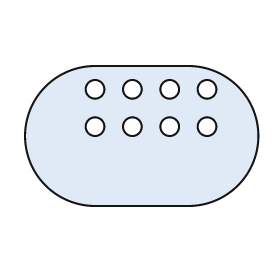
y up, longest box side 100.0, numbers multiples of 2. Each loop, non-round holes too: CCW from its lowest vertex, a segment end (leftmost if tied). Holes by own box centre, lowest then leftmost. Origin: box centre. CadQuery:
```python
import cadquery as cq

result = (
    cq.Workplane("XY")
    .moveTo(-20.0, -30.0)
    .lineTo(20.0, -30.0)
    .threePointArc((50.0, 0.0), (20.0, 30.0))
    .lineTo(-20.0, 30.0)
    .threePointArc((-50.0, 0.0), (-20.0, -30.0))
    .close()
    .moveTo(-20.0, 4.0)
    .circle(4.0)
    .moveTo(-4.0, 4.0)
    .circle(4.0)
    .moveTo(12.0, 4.0)
    .circle(4.0)
    .moveTo(28.0, 4.0)
    .circle(4.0)
    .moveTo(-20.0, 20.0)
    .circle(4.0)
    .moveTo(-4.0, 20.0)
    .circle(4.0)
    .moveTo(12.0, 20.0)
    .circle(4.0)
    .moveTo(28.0, 20.0)
    .circle(4.0)
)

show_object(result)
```